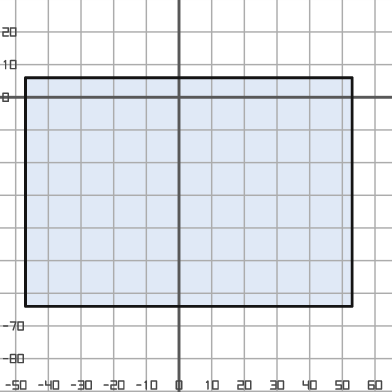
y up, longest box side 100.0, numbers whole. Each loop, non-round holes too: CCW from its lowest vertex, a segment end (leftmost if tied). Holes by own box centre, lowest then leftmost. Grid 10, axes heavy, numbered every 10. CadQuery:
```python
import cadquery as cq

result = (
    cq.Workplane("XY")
    .moveTo(-47.0, -64.0)
    .lineTo(53.0, -64.0)
    .lineTo(53.0, 6.0)
    .lineTo(-47.0, 6.0)
    .close()
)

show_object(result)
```